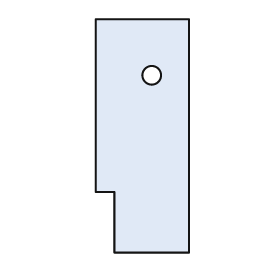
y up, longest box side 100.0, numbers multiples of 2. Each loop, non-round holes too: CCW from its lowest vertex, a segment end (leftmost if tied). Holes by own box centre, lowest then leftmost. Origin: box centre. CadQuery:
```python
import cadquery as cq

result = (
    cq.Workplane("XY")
    .moveTo(-12.0, -50.0)
    .lineTo(20.0, -50.0)
    .lineTo(20.0, 50.0)
    .lineTo(-20.0, 50.0)
    .lineTo(-20.0, -24.0)
    .lineTo(-12.0, -24.0)
    .close()
    .moveTo(4.0, 26.0)
    .circle(4.0)
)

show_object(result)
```